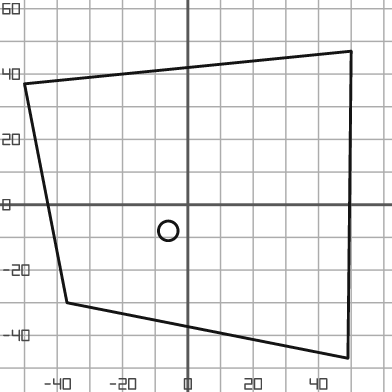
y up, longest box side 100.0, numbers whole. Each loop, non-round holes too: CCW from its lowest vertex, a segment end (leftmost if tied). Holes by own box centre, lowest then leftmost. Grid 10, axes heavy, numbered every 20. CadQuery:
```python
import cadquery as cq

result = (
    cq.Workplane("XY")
    .moveTo(49.0, -47.0)
    .lineTo(50.0, 47.0)
    .lineTo(-50.0, 37.0)
    .lineTo(-37.0, -30.0)
    .close()
    .moveTo(-6.0, -8.0)
    .circle(3.0)
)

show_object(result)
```